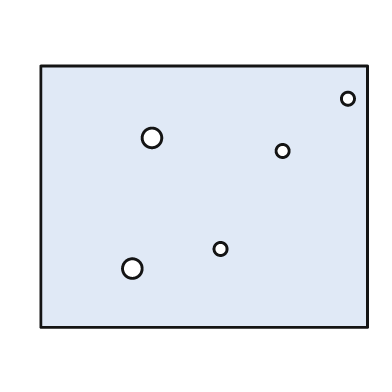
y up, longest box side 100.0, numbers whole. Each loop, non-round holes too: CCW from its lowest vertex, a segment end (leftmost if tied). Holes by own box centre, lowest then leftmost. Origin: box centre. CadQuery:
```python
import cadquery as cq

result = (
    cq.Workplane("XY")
    .moveTo(-50.0, -40.0)
    .lineTo(50.0, -40.0)
    .lineTo(50.0, 40.0)
    .lineTo(-50.0, 40.0)
    .close()
    .moveTo(-22.0, -22.0)
    .circle(3.0)
    .moveTo(5.0, -16.0)
    .circle(2.0)
    .moveTo(24.0, 14.0)
    .circle(2.0)
    .moveTo(-16.0, 18.0)
    .circle(3.0)
    .moveTo(44.0, 30.0)
    .circle(2.0)
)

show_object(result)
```